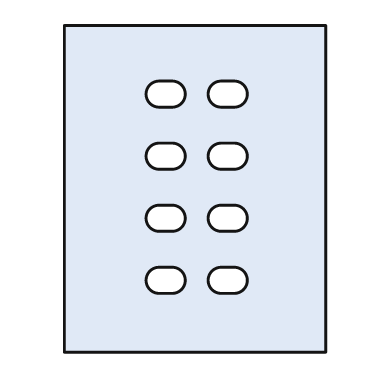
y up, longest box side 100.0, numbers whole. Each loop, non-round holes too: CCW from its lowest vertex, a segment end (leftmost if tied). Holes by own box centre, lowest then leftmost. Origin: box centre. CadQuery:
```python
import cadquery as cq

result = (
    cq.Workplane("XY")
    .moveTo(-40.0, -50.0)
    .lineTo(40.0, -50.0)
    .lineTo(40.0, 50.0)
    .lineTo(-40.0, 50.0)
    .close()
    .moveTo(-11.0, -32.0)
    .lineTo(-7.0, -32.0)
    .threePointArc((-3.0, -28.0), (-7.0, -24.0))
    .lineTo(-11.0, -24.0)
    .threePointArc((-15.0, -28.0), (-11.0, -32.0))
    .close()
    .moveTo(8.0, -32.0)
    .lineTo(12.0, -32.0)
    .threePointArc((16.0, -28.0), (12.0, -24.0))
    .lineTo(8.0, -24.0)
    .threePointArc((4.0, -28.0), (8.0, -32.0))
    .close()
    .moveTo(-11.0, -13.0)
    .lineTo(-7.0, -13.0)
    .threePointArc((-3.0, -9.0), (-7.0, -5.0))
    .lineTo(-11.0, -5.0)
    .threePointArc((-15.0, -9.0), (-11.0, -13.0))
    .close()
    .moveTo(8.0, -13.0)
    .lineTo(12.0, -13.0)
    .threePointArc((16.0, -9.0), (12.0, -5.0))
    .lineTo(8.0, -5.0)
    .threePointArc((4.0, -9.0), (8.0, -13.0))
    .close()
    .moveTo(-11.0, 6.0)
    .lineTo(-7.0, 6.0)
    .threePointArc((-3.0, 10.0), (-7.0, 14.0))
    .lineTo(-11.0, 14.0)
    .threePointArc((-15.0, 10.0), (-11.0, 6.0))
    .close()
    .moveTo(8.0, 6.0)
    .lineTo(12.0, 6.0)
    .threePointArc((16.0, 10.0), (12.0, 14.0))
    .lineTo(8.0, 14.0)
    .threePointArc((4.0, 10.0), (8.0, 6.0))
    .close()
    .moveTo(-11.0, 25.0)
    .lineTo(-7.0, 25.0)
    .threePointArc((-3.0, 29.0), (-7.0, 33.0))
    .lineTo(-11.0, 33.0)
    .threePointArc((-15.0, 29.0), (-11.0, 25.0))
    .close()
    .moveTo(8.0, 25.0)
    .lineTo(12.0, 25.0)
    .threePointArc((16.0, 29.0), (12.0, 33.0))
    .lineTo(8.0, 33.0)
    .threePointArc((4.0, 29.0), (8.0, 25.0))
    .close()
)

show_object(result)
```